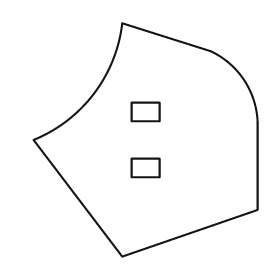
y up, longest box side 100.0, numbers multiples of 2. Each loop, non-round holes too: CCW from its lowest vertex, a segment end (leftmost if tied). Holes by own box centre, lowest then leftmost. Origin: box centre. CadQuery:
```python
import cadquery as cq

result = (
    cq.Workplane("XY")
    .moveTo(-10.0, -50.0)
    .lineTo(48.0, -30.0)
    .lineTo(48.0, 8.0)
    .threePointArc((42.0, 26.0), (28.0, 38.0))
    .lineTo(-10.0, 50.0)
    .threePointArc((-22.0, 20.0), (-48.0, 0.0))
    .close()
    .moveTo(-6.0, -16.0)
    .lineTo(6.0, -16.0)
    .lineTo(6.0, -8.0)
    .lineTo(-6.0, -8.0)
    .close()
    .moveTo(-6.0, 8.0)
    .lineTo(6.0, 8.0)
    .lineTo(6.0, 16.0)
    .lineTo(-6.0, 16.0)
    .close()
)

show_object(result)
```